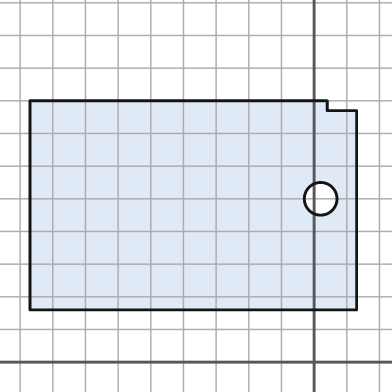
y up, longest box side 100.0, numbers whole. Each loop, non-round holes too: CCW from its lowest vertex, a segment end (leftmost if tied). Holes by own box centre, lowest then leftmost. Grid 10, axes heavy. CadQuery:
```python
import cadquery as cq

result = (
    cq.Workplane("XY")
    .moveTo(-87.0, 16.0)
    .lineTo(13.0, 16.0)
    .lineTo(13.0, 77.0)
    .lineTo(4.0, 77.0)
    .lineTo(4.0, 80.0)
    .lineTo(-87.0, 80.0)
    .close()
    .moveTo(2.0, 50.0)
    .circle(5.0)
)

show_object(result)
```